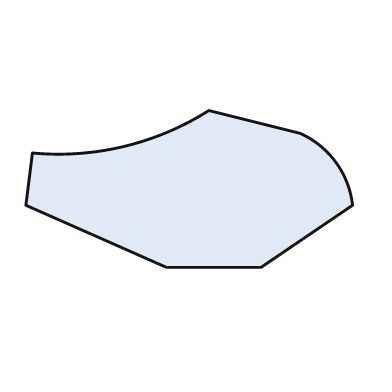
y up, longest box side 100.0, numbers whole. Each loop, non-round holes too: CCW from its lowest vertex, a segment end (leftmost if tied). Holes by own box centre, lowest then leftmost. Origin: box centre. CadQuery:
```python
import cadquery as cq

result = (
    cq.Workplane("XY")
    .moveTo(-7.0, -24.0)
    .lineTo(22.0, -24.0)
    .lineTo(50.0, -5.0)
    .threePointArc((45.0, 8.0), (34.0, 17.0))
    .lineTo(6.0, 24.0)
    .threePointArc((-20.0, 13.0), (-48.0, 11.0))
    .lineTo(-50.0, -5.0)
    .close()
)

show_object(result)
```